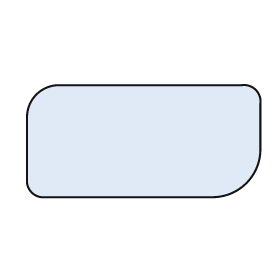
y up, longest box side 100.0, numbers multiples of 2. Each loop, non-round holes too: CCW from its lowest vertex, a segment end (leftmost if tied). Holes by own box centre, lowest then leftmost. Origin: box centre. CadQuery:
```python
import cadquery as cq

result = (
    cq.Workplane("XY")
    .moveTo(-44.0, -24.0)
    .lineTo(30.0, -24.0)
    .threePointArc((44.0, -18.0), (50.0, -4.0))
    .lineTo(50.0, 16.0)
    .threePointArc((48.0, 22.0), (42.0, 24.0))
    .lineTo(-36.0, 24.0)
    .threePointArc((-46.0, 20.0), (-50.0, 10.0))
    .lineTo(-50.0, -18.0)
    .threePointArc((-48.0, -22.0), (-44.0, -24.0))
    .close()
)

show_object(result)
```